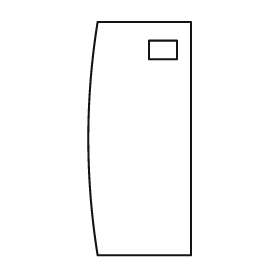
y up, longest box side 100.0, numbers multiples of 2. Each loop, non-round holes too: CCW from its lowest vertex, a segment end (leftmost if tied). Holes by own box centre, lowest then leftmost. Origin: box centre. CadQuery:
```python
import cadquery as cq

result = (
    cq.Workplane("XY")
    .moveTo(-18.0, -50.0)
    .lineTo(22.0, -50.0)
    .lineTo(22.0, 50.0)
    .lineTo(-18.0, 50.0)
    .threePointArc((-22.0, 0.0), (-18.0, -50.0))
    .close()
    .moveTo(4.0, 34.0)
    .lineTo(16.0, 34.0)
    .lineTo(16.0, 42.0)
    .lineTo(4.0, 42.0)
    .close()
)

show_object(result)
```